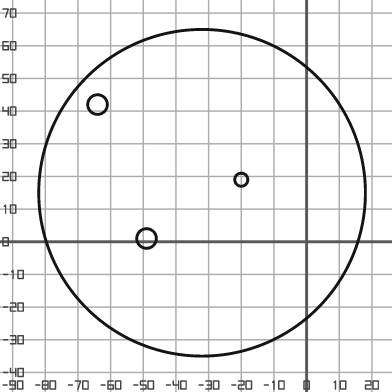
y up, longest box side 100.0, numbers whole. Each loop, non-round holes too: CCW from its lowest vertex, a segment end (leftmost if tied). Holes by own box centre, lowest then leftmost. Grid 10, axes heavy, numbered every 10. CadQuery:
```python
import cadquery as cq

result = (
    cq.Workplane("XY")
    .moveTo(-32.0, 15.0)
    .circle(50.0)
    .moveTo(-49.0, 1.0)
    .circle(3.0)
    .moveTo(-20.0, 19.0)
    .circle(2.0)
    .moveTo(-64.0, 42.0)
    .circle(3.0)
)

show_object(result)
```